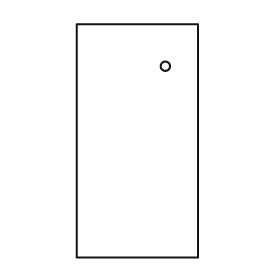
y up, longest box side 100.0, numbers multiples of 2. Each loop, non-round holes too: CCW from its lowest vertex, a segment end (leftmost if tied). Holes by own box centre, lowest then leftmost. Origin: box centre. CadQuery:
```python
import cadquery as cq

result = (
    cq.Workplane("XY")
    .moveTo(-26.0, -50.0)
    .lineTo(26.0, -50.0)
    .lineTo(26.0, 50.0)
    .lineTo(-26.0, 50.0)
    .close()
    .moveTo(12.0, 32.0)
    .circle(2.0)
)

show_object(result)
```